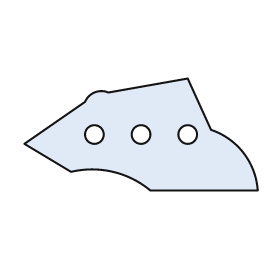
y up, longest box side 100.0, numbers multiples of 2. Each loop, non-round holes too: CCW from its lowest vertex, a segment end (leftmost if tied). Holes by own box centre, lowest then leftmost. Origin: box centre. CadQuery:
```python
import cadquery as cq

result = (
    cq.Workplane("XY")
    .moveTo(4.0, -24.0)
    .lineTo(50.0, -24.0)
    .threePointArc((44.0, -8.0), (30.0, 2.0))
    .lineTo(20.0, 24.0)
    .lineTo(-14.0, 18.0)
    .threePointArc((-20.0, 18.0), (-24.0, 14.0))
    .lineTo(-50.0, -4.0)
    .lineTo(-30.0, -16.0)
    .threePointArc((-12.0, -16.0), (4.0, -24.0))
    .close()
    .moveTo(-20.0, 0.0)
    .circle(4.0)
    .moveTo(0.0, 0.0)
    .circle(4.0)
    .moveTo(20.0, 0.0)
    .circle(4.0)
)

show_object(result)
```